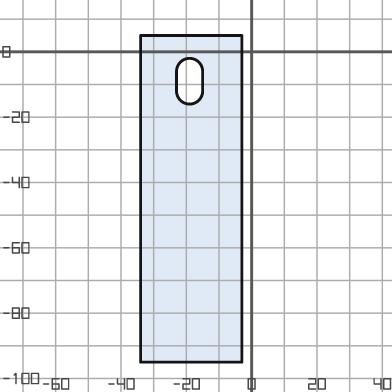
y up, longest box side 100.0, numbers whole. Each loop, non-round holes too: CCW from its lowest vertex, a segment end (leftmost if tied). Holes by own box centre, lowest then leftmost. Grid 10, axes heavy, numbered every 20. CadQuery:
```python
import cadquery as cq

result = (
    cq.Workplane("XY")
    .moveTo(-34.0, -95.0)
    .lineTo(-3.0, -95.0)
    .lineTo(-3.0, 5.0)
    .lineTo(-34.0, 5.0)
    .close()
    .moveTo(-23.0, -12.0)
    .threePointArc((-19.0, -16.0), (-15.0, -12.0))
    .lineTo(-15.0, -6.0)
    .threePointArc((-19.0, -2.0), (-23.0, -6.0))
    .close()
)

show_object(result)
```